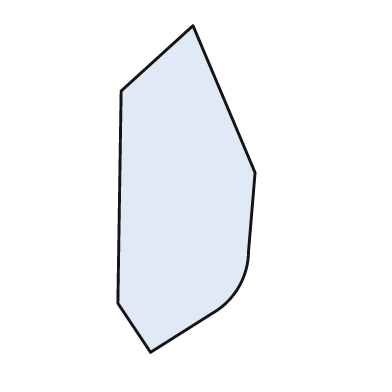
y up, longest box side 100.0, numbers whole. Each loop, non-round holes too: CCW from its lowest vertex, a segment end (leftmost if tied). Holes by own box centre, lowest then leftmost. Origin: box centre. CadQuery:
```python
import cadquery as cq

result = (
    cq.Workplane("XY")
    .moveTo(-11.0, -50.0)
    .lineTo(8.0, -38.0)
    .threePointArc((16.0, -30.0), (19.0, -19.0))
    .lineTo(21.0, 5.0)
    .lineTo(2.0, 50.0)
    .lineTo(-20.0, 30.0)
    .lineTo(-21.0, -35.0)
    .close()
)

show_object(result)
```